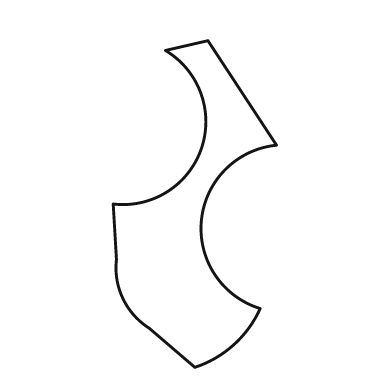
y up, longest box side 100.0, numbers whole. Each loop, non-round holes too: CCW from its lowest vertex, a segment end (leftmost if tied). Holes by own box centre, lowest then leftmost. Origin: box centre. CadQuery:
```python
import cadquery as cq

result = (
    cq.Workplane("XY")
    .moveTo(0.0, -50.0)
    .threePointArc((12.0, -43.0), (20.0, -32.0))
    .threePointArc((2.0, -5.0), (25.0, 18.0))
    .lineTo(4.0, 50.0)
    .lineTo(-9.0, 47.0)
    .threePointArc((2.0, 17.0), (-25.0, 0.0))
    .lineTo(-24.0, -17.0)
    .threePointArc((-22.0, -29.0), (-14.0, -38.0))
    .close()
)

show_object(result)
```